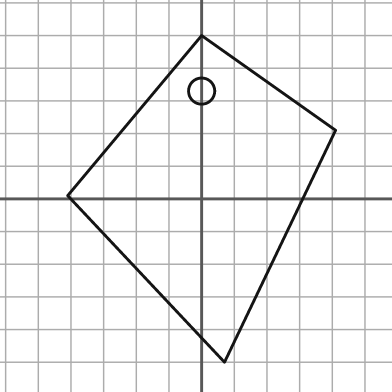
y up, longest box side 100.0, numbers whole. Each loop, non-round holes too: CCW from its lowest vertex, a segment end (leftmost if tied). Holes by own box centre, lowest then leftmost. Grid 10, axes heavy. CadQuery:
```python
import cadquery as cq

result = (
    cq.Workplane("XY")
    .moveTo(7.0, -50.0)
    .lineTo(41.0, 21.0)
    .lineTo(0.0, 50.0)
    .lineTo(-41.0, 1.0)
    .close()
    .moveTo(0.0, 33.0)
    .circle(4.0)
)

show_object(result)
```